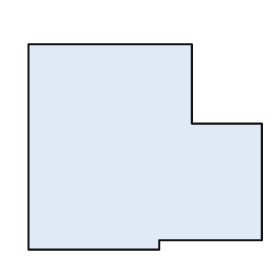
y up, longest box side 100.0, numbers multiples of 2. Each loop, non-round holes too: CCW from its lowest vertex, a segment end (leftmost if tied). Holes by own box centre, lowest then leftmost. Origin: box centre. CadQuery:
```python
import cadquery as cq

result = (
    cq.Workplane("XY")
    .moveTo(-50.0, -44.0)
    .lineTo(6.0, -44.0)
    .lineTo(6.0, -40.0)
    .lineTo(50.0, -40.0)
    .lineTo(50.0, 10.0)
    .lineTo(20.0, 10.0)
    .lineTo(20.0, 44.0)
    .lineTo(-50.0, 44.0)
    .close()
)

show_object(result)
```